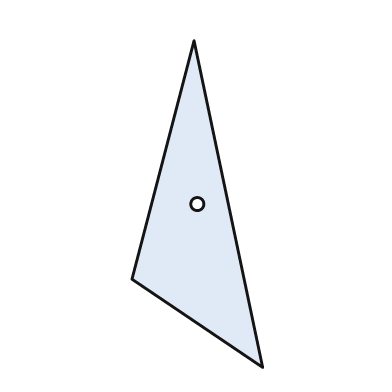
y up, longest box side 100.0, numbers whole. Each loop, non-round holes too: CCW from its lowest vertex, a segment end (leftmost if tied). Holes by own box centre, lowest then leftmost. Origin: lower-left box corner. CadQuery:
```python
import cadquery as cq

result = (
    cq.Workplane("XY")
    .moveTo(40.0, 0.0)
    .lineTo(19.0, 100.0)
    .lineTo(0.0, 27.0)
    .close()
    .moveTo(20.0, 50.0)
    .circle(2.0)
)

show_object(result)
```